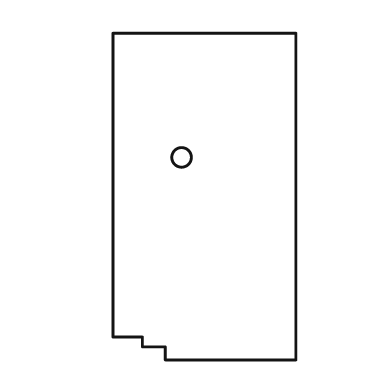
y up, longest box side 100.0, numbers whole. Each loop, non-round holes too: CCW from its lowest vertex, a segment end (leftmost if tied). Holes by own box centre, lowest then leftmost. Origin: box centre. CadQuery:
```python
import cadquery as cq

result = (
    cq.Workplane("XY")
    .moveTo(-12.0, -50.0)
    .lineTo(28.0, -50.0)
    .lineTo(28.0, 50.0)
    .lineTo(-28.0, 50.0)
    .lineTo(-28.0, -43.0)
    .lineTo(-19.0, -43.0)
    .lineTo(-19.0, -46.0)
    .lineTo(-12.0, -46.0)
    .close()
    .moveTo(-7.0, 12.0)
    .circle(3.0)
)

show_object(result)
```